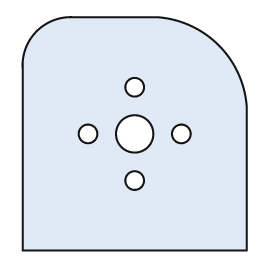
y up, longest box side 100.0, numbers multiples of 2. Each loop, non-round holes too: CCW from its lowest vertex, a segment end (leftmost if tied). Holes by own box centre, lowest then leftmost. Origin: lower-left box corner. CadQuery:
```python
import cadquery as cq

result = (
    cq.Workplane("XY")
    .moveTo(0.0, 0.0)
    .lineTo(96.0, 0.0)
    .lineTo(96.0, 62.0)
    .threePointArc((84.0, 88.0), (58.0, 100.0))
    .lineTo(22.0, 100.0)
    .threePointArc((6.0, 94.0), (0.0, 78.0))
    .close()
    .moveTo(48.0, 30.0)
    .circle(4.0)
    .moveTo(28.0, 50.0)
    .circle(4.0)
    .moveTo(48.0, 50.0)
    .circle(8.0)
    .moveTo(68.0, 50.0)
    .circle(4.0)
    .moveTo(48.0, 70.0)
    .circle(4.0)
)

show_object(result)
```